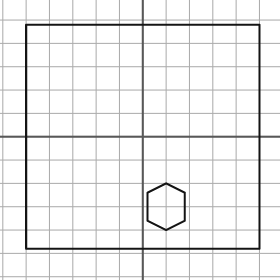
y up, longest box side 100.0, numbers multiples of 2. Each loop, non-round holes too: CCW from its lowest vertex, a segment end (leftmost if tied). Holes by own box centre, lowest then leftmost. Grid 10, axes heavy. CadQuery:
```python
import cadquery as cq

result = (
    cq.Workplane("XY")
    .moveTo(-50.0, -48.0)
    .lineTo(50.0, -48.0)
    .lineTo(50.0, 48.0)
    .lineTo(-50.0, 48.0)
    .close()
    .moveTo(10.0, -40.0)
    .lineTo(18.0, -36.0)
    .lineTo(18.0, -24.0)
    .lineTo(10.0, -20.0)
    .lineTo(2.0, -24.0)
    .lineTo(2.0, -36.0)
    .close()
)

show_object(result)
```